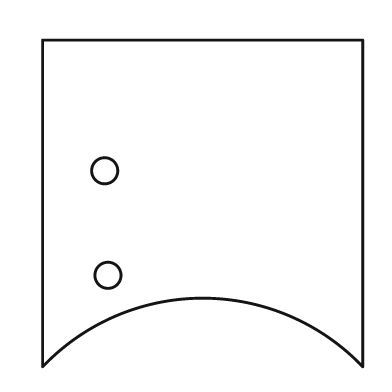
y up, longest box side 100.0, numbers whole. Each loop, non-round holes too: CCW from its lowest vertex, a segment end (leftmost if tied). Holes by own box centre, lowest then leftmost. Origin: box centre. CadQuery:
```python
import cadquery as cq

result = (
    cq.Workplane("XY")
    .moveTo(-49.0, -50.0)
    .threePointArc((0.0, -29.0), (49.0, -50.0))
    .lineTo(49.0, 50.0)
    .lineTo(-49.0, 50.0)
    .close()
    .moveTo(-29.0, -22.0)
    .circle(4.0)
    .moveTo(-30.0, 10.0)
    .circle(4.0)
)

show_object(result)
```